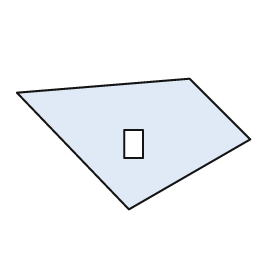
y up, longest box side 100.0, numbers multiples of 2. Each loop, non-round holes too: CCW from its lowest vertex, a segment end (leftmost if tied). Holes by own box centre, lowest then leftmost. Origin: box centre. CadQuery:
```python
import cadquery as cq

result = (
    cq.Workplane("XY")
    .moveTo(-2.0, -28.0)
    .lineTo(50.0, 2.0)
    .lineTo(24.0, 28.0)
    .lineTo(-50.0, 22.0)
    .close()
    .moveTo(-4.0, -6.0)
    .lineTo(4.0, -6.0)
    .lineTo(4.0, 6.0)
    .lineTo(-4.0, 6.0)
    .close()
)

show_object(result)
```